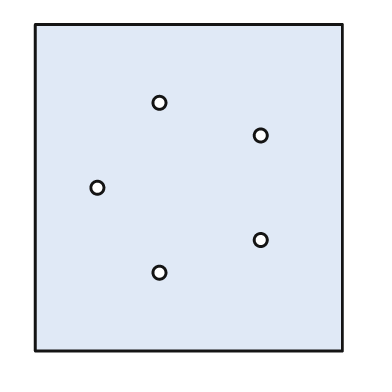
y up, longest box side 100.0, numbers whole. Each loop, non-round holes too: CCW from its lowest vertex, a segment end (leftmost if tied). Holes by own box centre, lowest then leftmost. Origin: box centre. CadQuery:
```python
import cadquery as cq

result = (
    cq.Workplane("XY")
    .moveTo(-47.0, -50.0)
    .lineTo(47.0, -50.0)
    .lineTo(47.0, 50.0)
    .lineTo(-47.0, 50.0)
    .close()
    .moveTo(-9.0, -26.0)
    .circle(2.0)
    .moveTo(22.0, -16.0)
    .circle(2.0)
    .moveTo(-28.0, 0.0)
    .circle(2.0)
    .moveTo(22.0, 16.0)
    .circle(2.0)
    .moveTo(-9.0, 26.0)
    .circle(2.0)
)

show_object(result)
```